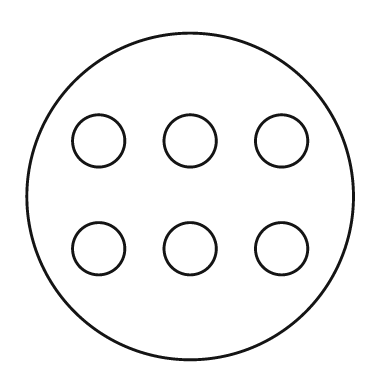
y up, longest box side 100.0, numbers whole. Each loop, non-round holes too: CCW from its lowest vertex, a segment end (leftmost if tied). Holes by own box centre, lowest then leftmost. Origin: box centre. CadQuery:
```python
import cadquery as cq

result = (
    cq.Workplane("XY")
    .moveTo(0.0, 0.0)
    .circle(50.0)
    .moveTo(-28.0, -16.0)
    .circle(8.0)
    .moveTo(0.0, -16.0)
    .circle(8.0)
    .moveTo(28.0, -16.0)
    .circle(8.0)
    .moveTo(-28.0, 17.0)
    .circle(8.0)
    .moveTo(0.0, 17.0)
    .circle(8.0)
    .moveTo(28.0, 17.0)
    .circle(8.0)
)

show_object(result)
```